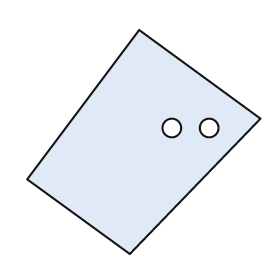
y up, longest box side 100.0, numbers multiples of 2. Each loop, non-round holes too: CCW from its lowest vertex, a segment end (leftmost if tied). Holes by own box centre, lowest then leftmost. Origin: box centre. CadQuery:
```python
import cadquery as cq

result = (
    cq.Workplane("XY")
    .moveTo(-6.0, -48.0)
    .lineTo(50.0, 10.0)
    .lineTo(-2.0, 48.0)
    .lineTo(-50.0, -16.0)
    .close()
    .moveTo(12.0, 6.0)
    .circle(4.0)
    .moveTo(28.0, 6.0)
    .circle(4.0)
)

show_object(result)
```